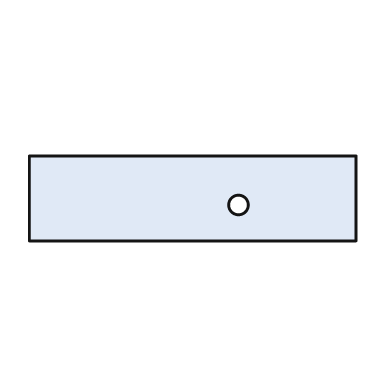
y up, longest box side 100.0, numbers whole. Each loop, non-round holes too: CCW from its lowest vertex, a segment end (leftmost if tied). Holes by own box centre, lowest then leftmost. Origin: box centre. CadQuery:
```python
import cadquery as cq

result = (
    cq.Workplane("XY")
    .moveTo(-50.0, -13.0)
    .lineTo(50.0, -13.0)
    .lineTo(50.0, 13.0)
    .lineTo(-50.0, 13.0)
    .close()
    .moveTo(14.0, -2.0)
    .circle(3.0)
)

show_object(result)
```